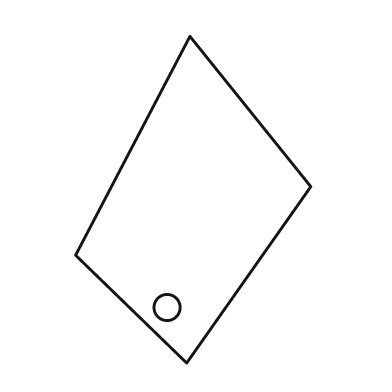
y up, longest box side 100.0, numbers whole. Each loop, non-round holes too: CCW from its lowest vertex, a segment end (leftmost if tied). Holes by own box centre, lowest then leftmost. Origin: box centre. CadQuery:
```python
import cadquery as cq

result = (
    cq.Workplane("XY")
    .moveTo(-2.0, -50.0)
    .lineTo(36.0, 4.0)
    .lineTo(-1.0, 50.0)
    .lineTo(-36.0, -17.0)
    .close()
    .moveTo(-8.0, -33.0)
    .circle(4.0)
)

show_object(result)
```